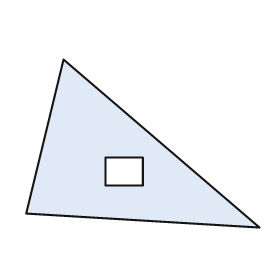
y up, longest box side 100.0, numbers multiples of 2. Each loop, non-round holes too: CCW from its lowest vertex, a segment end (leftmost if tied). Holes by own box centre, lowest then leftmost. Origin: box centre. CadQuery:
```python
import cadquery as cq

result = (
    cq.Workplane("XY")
    .moveTo(50.0, -36.0)
    .lineTo(-34.0, 36.0)
    .lineTo(-50.0, -30.0)
    .close()
    .moveTo(-16.0, -18.0)
    .lineTo(0.0, -18.0)
    .lineTo(0.0, -6.0)
    .lineTo(-16.0, -6.0)
    .close()
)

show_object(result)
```